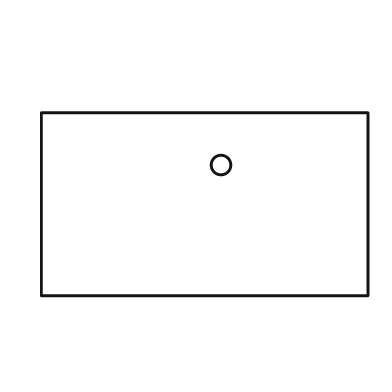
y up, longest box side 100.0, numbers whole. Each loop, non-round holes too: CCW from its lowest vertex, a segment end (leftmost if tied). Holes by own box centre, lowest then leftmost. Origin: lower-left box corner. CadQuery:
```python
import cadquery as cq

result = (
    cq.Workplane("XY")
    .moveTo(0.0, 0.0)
    .lineTo(100.0, 0.0)
    .lineTo(100.0, 56.0)
    .lineTo(0.0, 56.0)
    .close()
    .moveTo(55.0, 40.0)
    .circle(3.0)
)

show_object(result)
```